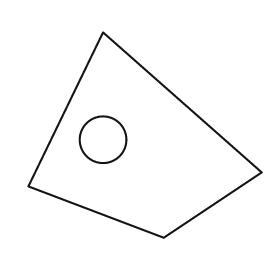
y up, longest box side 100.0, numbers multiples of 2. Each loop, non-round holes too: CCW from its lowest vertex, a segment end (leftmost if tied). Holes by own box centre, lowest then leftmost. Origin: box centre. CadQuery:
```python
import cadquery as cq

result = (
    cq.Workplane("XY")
    .moveTo(8.0, -44.0)
    .lineTo(50.0, -16.0)
    .lineTo(-18.0, 44.0)
    .lineTo(-50.0, -22.0)
    .close()
    .moveTo(-18.0, -2.0)
    .circle(10.0)
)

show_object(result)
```